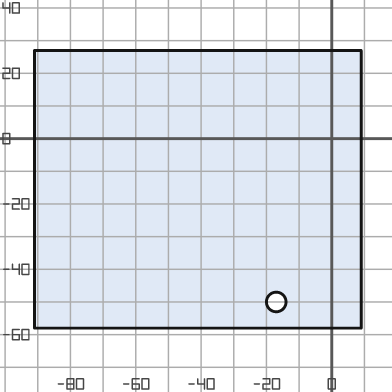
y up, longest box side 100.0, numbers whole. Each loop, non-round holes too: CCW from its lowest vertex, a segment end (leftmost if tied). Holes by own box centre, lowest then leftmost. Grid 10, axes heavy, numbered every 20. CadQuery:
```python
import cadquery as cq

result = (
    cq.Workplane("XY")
    .moveTo(-91.0, -58.0)
    .lineTo(9.0, -58.0)
    .lineTo(9.0, 27.0)
    .lineTo(-91.0, 27.0)
    .close()
    .moveTo(-17.0, -50.0)
    .circle(3.0)
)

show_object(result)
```